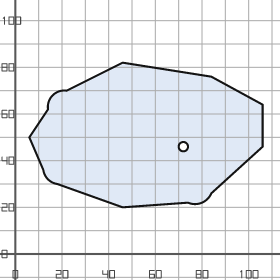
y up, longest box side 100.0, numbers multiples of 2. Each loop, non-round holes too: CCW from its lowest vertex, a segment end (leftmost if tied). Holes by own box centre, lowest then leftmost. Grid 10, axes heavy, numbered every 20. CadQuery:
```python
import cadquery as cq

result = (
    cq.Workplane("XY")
    .moveTo(46.0, 20.0)
    .lineTo(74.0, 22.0)
    .threePointArc((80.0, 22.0), (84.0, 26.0))
    .lineTo(106.0, 46.0)
    .lineTo(106.0, 64.0)
    .lineTo(84.0, 76.0)
    .lineTo(46.0, 82.0)
    .lineTo(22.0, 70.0)
    .threePointArc((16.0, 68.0), (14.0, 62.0))
    .lineTo(6.0, 50.0)
    .lineTo(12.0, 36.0)
    .threePointArc((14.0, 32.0), (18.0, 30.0))
    .close()
    .moveTo(72.0, 46.0)
    .circle(2.0)
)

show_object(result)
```